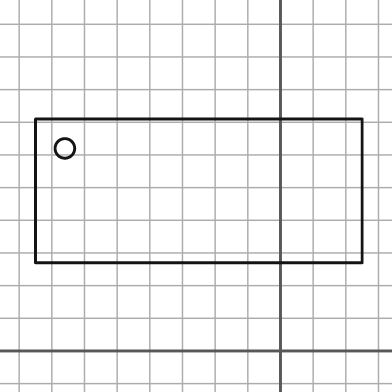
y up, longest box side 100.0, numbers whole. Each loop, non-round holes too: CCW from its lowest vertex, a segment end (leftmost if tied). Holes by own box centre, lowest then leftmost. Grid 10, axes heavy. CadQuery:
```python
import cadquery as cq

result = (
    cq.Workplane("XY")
    .moveTo(-75.0, 27.0)
    .lineTo(25.0, 27.0)
    .lineTo(25.0, 71.0)
    .lineTo(-75.0, 71.0)
    .close()
    .moveTo(-66.0, 62.0)
    .circle(3.0)
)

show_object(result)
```